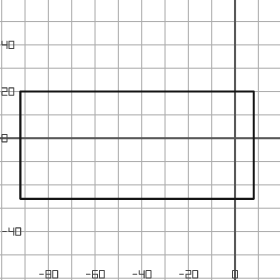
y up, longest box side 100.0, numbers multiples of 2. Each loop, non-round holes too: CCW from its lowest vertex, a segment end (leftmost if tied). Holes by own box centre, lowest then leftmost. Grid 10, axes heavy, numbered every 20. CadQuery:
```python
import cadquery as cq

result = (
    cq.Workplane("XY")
    .moveTo(-92.0, -26.0)
    .lineTo(8.0, -26.0)
    .lineTo(8.0, 20.0)
    .lineTo(-92.0, 20.0)
    .close()
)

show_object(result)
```